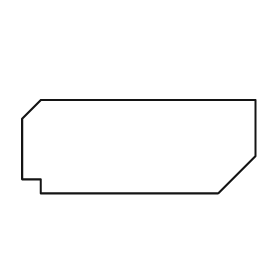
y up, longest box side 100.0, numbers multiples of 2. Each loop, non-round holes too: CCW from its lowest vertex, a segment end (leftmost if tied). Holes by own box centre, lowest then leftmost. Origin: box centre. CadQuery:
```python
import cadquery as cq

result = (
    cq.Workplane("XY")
    .moveTo(-42.0, -20.0)
    .lineTo(34.0, -20.0)
    .lineTo(50.0, -4.0)
    .lineTo(50.0, 20.0)
    .lineTo(-42.0, 20.0)
    .lineTo(-50.0, 12.0)
    .lineTo(-50.0, -14.0)
    .lineTo(-42.0, -14.0)
    .close()
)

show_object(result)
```